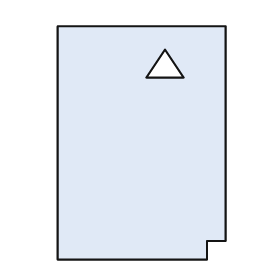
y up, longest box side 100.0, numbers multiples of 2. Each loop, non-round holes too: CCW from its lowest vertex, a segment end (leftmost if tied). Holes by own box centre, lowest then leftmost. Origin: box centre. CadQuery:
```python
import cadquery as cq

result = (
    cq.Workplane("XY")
    .moveTo(-36.0, -50.0)
    .lineTo(28.0, -50.0)
    .lineTo(28.0, -42.0)
    .lineTo(36.0, -42.0)
    .lineTo(36.0, 50.0)
    .lineTo(-36.0, 50.0)
    .close()
    .moveTo(2.0, 28.0)
    .lineTo(18.0, 28.0)
    .lineTo(10.0, 40.0)
    .close()
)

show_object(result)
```